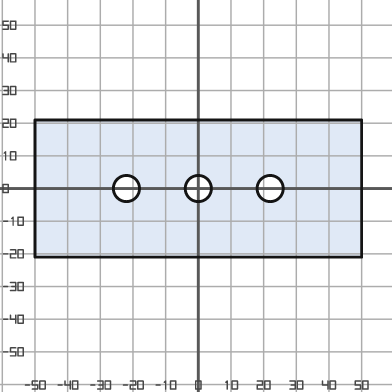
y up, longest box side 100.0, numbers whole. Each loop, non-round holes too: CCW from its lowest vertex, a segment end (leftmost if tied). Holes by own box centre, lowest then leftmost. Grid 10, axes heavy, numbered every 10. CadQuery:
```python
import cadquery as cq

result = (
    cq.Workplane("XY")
    .moveTo(-50.0, -21.0)
    .lineTo(50.0, -21.0)
    .lineTo(50.0, 21.0)
    .lineTo(-50.0, 21.0)
    .close()
    .moveTo(-22.0, 0.0)
    .circle(4.0)
    .moveTo(0.0, 0.0)
    .circle(4.0)
    .moveTo(22.0, 0.0)
    .circle(4.0)
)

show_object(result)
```